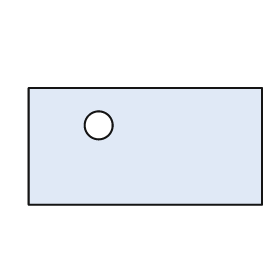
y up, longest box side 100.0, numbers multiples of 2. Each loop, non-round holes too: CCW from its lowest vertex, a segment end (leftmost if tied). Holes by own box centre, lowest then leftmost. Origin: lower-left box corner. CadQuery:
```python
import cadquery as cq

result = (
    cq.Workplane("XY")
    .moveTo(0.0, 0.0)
    .lineTo(100.0, 0.0)
    .lineTo(100.0, 50.0)
    .lineTo(0.0, 50.0)
    .close()
    .moveTo(30.0, 34.0)
    .circle(6.0)
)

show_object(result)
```